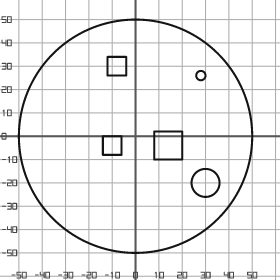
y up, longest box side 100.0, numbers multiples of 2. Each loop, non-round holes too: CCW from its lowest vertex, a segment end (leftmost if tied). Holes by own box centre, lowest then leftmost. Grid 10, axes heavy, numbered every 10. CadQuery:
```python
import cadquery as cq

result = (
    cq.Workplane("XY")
    .moveTo(0.0, 0.0)
    .circle(50.0)
    .moveTo(30.0, -20.0)
    .circle(6.0)
    .moveTo(-14.0, -8.0)
    .lineTo(-6.0, -8.0)
    .lineTo(-6.0, 0.0)
    .lineTo(-14.0, 0.0)
    .close()
    .moveTo(8.0, -10.0)
    .lineTo(20.0, -10.0)
    .lineTo(20.0, 2.0)
    .lineTo(8.0, 2.0)
    .close()
    .moveTo(28.0, 26.0)
    .circle(2.0)
    .moveTo(-12.0, 26.0)
    .lineTo(-4.0, 26.0)
    .lineTo(-4.0, 34.0)
    .lineTo(-12.0, 34.0)
    .close()
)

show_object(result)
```